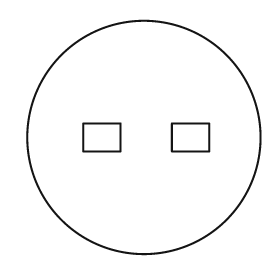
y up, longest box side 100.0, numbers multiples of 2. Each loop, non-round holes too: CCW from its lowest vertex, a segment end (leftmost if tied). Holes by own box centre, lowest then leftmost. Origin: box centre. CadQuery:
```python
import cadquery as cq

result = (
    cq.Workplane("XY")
    .moveTo(0.0, 0.0)
    .circle(50.0)
    .moveTo(-26.0, -6.0)
    .lineTo(-10.0, -6.0)
    .lineTo(-10.0, 6.0)
    .lineTo(-26.0, 6.0)
    .close()
    .moveTo(12.0, -6.0)
    .lineTo(28.0, -6.0)
    .lineTo(28.0, 6.0)
    .lineTo(12.0, 6.0)
    .close()
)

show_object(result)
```